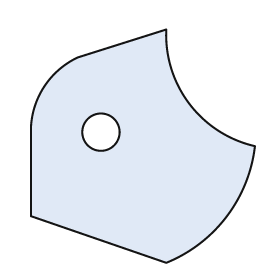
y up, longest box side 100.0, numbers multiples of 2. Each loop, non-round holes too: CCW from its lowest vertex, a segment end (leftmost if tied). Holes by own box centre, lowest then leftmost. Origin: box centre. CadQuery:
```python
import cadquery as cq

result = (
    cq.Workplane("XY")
    .moveTo(10.0, -50.0)
    .threePointArc((36.0, -30.0), (48.0, 0.0))
    .threePointArc((20.0, 18.0), (10.0, 50.0))
    .lineTo(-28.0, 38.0)
    .threePointArc((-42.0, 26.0), (-48.0, 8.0))
    .lineTo(-48.0, -30.0)
    .close()
    .moveTo(-18.0, 6.0)
    .circle(8.0)
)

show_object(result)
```